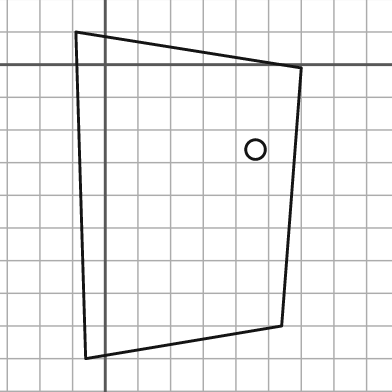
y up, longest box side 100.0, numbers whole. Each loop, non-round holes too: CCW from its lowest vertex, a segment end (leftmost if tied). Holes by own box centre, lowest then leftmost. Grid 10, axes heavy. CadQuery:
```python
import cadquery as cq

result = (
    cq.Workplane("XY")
    .moveTo(-6.0, -90.0)
    .lineTo(54.0, -80.0)
    .lineTo(60.0, -1.0)
    .lineTo(-9.0, 10.0)
    .close()
    .moveTo(46.0, -26.0)
    .circle(3.0)
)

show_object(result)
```